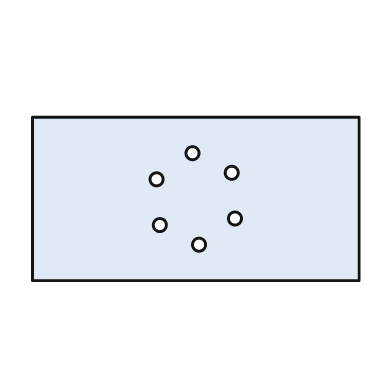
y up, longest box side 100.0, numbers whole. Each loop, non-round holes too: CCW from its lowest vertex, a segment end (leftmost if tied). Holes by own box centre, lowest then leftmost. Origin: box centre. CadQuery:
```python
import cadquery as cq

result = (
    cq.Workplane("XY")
    .moveTo(-50.0, -25.0)
    .lineTo(50.0, -25.0)
    .lineTo(50.0, 25.0)
    .lineTo(-50.0, 25.0)
    .close()
    .moveTo(1.0, -14.0)
    .circle(2.0)
    .moveTo(-11.0, -8.0)
    .circle(2.0)
    .moveTo(12.0, -6.0)
    .circle(2.0)
    .moveTo(-12.0, 6.0)
    .circle(2.0)
    .moveTo(11.0, 8.0)
    .circle(2.0)
    .moveTo(-1.0, 14.0)
    .circle(2.0)
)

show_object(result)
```